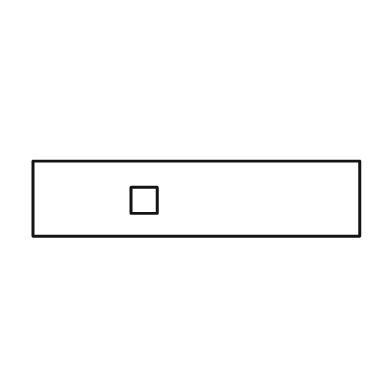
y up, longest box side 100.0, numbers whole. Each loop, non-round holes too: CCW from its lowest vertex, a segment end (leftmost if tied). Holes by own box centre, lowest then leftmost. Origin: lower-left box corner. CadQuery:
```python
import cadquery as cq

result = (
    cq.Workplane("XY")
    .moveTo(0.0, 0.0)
    .lineTo(100.0, 0.0)
    .lineTo(100.0, 23.0)
    .lineTo(0.0, 23.0)
    .close()
    .moveTo(30.0, 7.0)
    .lineTo(38.0, 7.0)
    .lineTo(38.0, 15.0)
    .lineTo(30.0, 15.0)
    .close()
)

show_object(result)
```